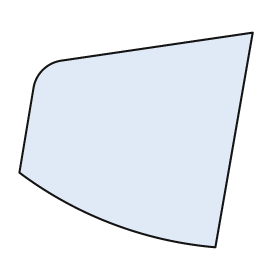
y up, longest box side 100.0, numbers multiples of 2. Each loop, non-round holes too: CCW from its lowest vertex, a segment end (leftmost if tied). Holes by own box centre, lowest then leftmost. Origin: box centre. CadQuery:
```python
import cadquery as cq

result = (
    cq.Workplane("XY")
    .moveTo(34.0, -46.0)
    .lineTo(50.0, 46.0)
    .lineTo(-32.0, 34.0)
    .threePointArc((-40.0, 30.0), (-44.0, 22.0))
    .lineTo(-50.0, -14.0)
    .threePointArc((-10.0, -36.0), (34.0, -46.0))
    .close()
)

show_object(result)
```